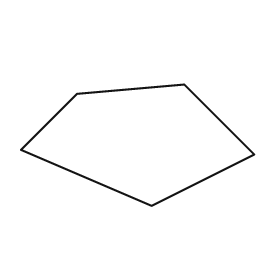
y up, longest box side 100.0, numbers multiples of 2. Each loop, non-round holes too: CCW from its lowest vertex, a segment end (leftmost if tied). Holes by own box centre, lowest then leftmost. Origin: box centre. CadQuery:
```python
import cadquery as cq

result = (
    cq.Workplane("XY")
    .moveTo(6.0, -26.0)
    .lineTo(50.0, -4.0)
    .lineTo(20.0, 26.0)
    .lineTo(-26.0, 22.0)
    .lineTo(-50.0, -2.0)
    .close()
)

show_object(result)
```